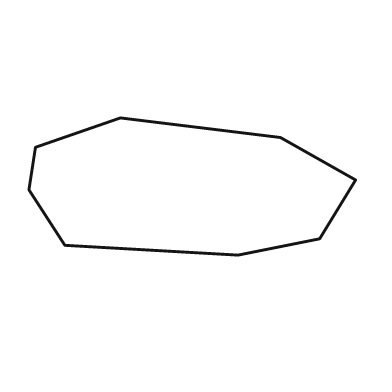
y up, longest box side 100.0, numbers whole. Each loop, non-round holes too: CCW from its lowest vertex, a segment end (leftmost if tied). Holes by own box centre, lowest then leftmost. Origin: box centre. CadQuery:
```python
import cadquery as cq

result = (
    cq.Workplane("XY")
    .moveTo(14.0, -21.0)
    .lineTo(39.0, -16.0)
    .lineTo(50.0, 2.0)
    .lineTo(27.0, 15.0)
    .lineTo(-22.0, 21.0)
    .lineTo(-48.0, 12.0)
    .lineTo(-50.0, -1.0)
    .lineTo(-39.0, -18.0)
    .close()
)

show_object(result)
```